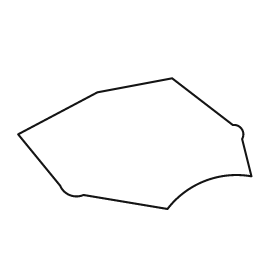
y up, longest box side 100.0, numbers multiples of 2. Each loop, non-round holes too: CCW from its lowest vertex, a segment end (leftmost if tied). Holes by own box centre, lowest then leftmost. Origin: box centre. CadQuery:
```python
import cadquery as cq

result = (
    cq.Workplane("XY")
    .moveTo(14.0, -28.0)
    .threePointArc((30.0, -16.0), (50.0, -14.0))
    .lineTo(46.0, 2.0)
    .threePointArc((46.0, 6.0), (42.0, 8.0))
    .lineTo(16.0, 28.0)
    .lineTo(-16.0, 22.0)
    .lineTo(-50.0, 4.0)
    .lineTo(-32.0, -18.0)
    .threePointArc((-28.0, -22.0), (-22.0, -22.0))
    .close()
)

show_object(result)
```